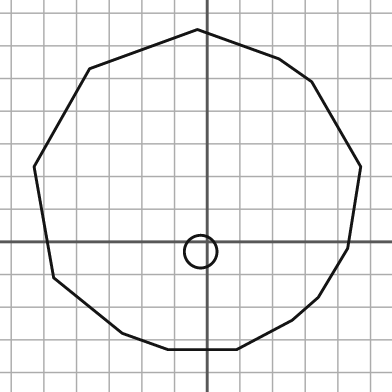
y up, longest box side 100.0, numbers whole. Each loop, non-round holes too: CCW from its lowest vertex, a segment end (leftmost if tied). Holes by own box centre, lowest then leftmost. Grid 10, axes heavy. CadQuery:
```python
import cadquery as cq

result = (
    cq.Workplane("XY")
    .moveTo(-12.0, -33.0)
    .lineTo(9.0, -33.0)
    .lineTo(26.0, -24.0)
    .lineTo(34.0, -17.0)
    .lineTo(43.0, -2.0)
    .lineTo(47.0, 23.0)
    .lineTo(32.0, 49.0)
    .lineTo(22.0, 56.0)
    .lineTo(-3.0, 65.0)
    .lineTo(-36.0, 53.0)
    .lineTo(-53.0, 23.0)
    .lineTo(-47.0, -11.0)
    .lineTo(-26.0, -28.0)
    .close()
    .moveTo(-2.0, -3.0)
    .circle(5.0)
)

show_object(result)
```